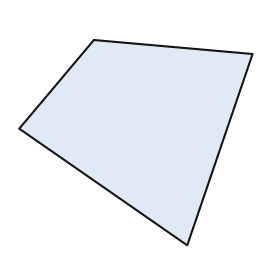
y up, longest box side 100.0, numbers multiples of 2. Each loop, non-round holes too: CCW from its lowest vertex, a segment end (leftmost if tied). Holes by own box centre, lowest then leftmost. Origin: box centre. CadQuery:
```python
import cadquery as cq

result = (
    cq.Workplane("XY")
    .moveTo(22.0, -44.0)
    .lineTo(50.0, 38.0)
    .lineTo(-18.0, 44.0)
    .lineTo(-50.0, 6.0)
    .close()
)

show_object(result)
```